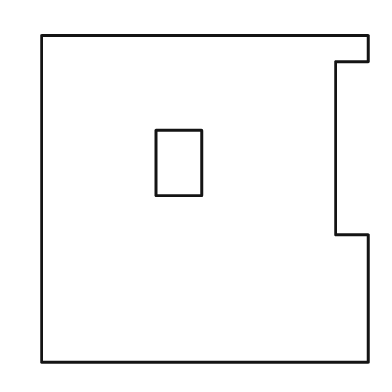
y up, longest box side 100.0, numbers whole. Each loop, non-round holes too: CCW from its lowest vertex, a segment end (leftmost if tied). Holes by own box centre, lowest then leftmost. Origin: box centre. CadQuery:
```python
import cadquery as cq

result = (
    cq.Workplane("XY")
    .moveTo(-50.0, -50.0)
    .lineTo(50.0, -50.0)
    .lineTo(50.0, -11.0)
    .lineTo(40.0, -11.0)
    .lineTo(40.0, 42.0)
    .lineTo(50.0, 42.0)
    .lineTo(50.0, 50.0)
    .lineTo(-50.0, 50.0)
    .close()
    .moveTo(-15.0, 1.0)
    .lineTo(-1.0, 1.0)
    .lineTo(-1.0, 21.0)
    .lineTo(-15.0, 21.0)
    .close()
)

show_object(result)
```